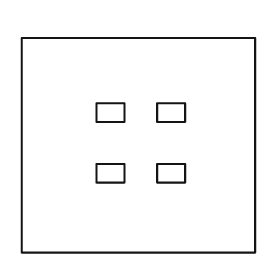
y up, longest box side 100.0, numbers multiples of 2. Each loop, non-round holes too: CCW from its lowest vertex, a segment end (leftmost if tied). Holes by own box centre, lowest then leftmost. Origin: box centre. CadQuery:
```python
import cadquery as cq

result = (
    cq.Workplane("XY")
    .moveTo(-50.0, -46.0)
    .lineTo(50.0, -46.0)
    .lineTo(50.0, 46.0)
    .lineTo(-50.0, 46.0)
    .close()
    .moveTo(-18.0, -16.0)
    .lineTo(-6.0, -16.0)
    .lineTo(-6.0, -8.0)
    .lineTo(-18.0, -8.0)
    .close()
    .moveTo(8.0, -16.0)
    .lineTo(20.0, -16.0)
    .lineTo(20.0, -8.0)
    .lineTo(8.0, -8.0)
    .close()
    .moveTo(-18.0, 10.0)
    .lineTo(-6.0, 10.0)
    .lineTo(-6.0, 18.0)
    .lineTo(-18.0, 18.0)
    .close()
    .moveTo(8.0, 10.0)
    .lineTo(20.0, 10.0)
    .lineTo(20.0, 18.0)
    .lineTo(8.0, 18.0)
    .close()
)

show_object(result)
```